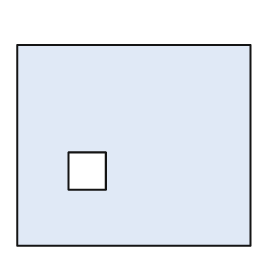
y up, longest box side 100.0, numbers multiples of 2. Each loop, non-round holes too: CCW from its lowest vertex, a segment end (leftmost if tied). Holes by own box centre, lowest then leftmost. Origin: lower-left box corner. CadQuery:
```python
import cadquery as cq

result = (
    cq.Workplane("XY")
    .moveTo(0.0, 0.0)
    .lineTo(100.0, 0.0)
    .lineTo(100.0, 86.0)
    .lineTo(0.0, 86.0)
    .close()
    .moveTo(22.0, 24.0)
    .lineTo(38.0, 24.0)
    .lineTo(38.0, 40.0)
    .lineTo(22.0, 40.0)
    .close()
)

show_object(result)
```